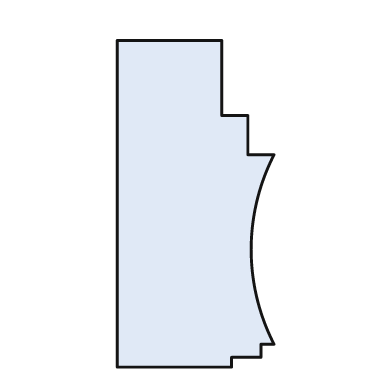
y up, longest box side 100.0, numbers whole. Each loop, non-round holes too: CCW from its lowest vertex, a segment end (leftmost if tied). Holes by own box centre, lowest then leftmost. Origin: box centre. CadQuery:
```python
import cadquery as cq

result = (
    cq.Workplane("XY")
    .moveTo(-24.0, -50.0)
    .lineTo(11.0, -50.0)
    .lineTo(11.0, -47.0)
    .lineTo(20.0, -47.0)
    .lineTo(20.0, -43.0)
    .lineTo(24.0, -43.0)
    .threePointArc((17.0, -14.0), (24.0, 15.0))
    .lineTo(16.0, 15.0)
    .lineTo(16.0, 27.0)
    .lineTo(8.0, 27.0)
    .lineTo(8.0, 50.0)
    .lineTo(-24.0, 50.0)
    .close()
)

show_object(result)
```